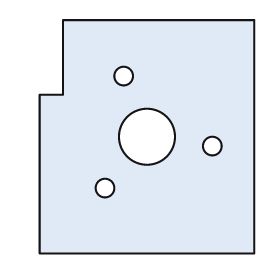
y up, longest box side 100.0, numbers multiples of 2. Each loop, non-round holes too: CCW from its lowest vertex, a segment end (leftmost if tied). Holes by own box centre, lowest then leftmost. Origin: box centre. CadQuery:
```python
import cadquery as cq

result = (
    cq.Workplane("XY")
    .moveTo(-46.0, -50.0)
    .lineTo(46.0, -50.0)
    .lineTo(46.0, 50.0)
    .lineTo(-36.0, 50.0)
    .lineTo(-36.0, 18.0)
    .lineTo(-46.0, 18.0)
    .close()
    .moveTo(-18.0, -22.0)
    .circle(4.0)
    .moveTo(28.0, -4.0)
    .circle(4.0)
    .moveTo(0.0, 0.0)
    .circle(12.0)
    .moveTo(-10.0, 26.0)
    .circle(4.0)
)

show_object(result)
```